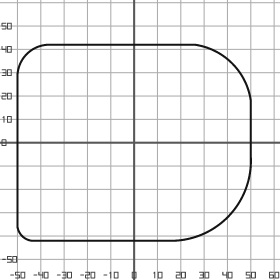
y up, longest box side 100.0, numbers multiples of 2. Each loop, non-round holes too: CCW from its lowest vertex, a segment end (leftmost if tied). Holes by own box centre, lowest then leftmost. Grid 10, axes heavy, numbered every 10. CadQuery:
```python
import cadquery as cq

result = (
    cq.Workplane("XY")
    .moveTo(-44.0, -42.0)
    .lineTo(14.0, -42.0)
    .threePointArc((40.0, -32.0), (50.0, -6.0))
    .lineTo(50.0, 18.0)
    .threePointArc((42.0, 34.0), (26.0, 42.0))
    .lineTo(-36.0, 42.0)
    .threePointArc((-46.0, 38.0), (-50.0, 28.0))
    .lineTo(-50.0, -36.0)
    .threePointArc((-48.0, -40.0), (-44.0, -42.0))
    .close()
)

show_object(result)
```